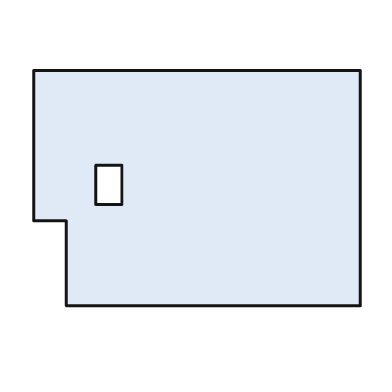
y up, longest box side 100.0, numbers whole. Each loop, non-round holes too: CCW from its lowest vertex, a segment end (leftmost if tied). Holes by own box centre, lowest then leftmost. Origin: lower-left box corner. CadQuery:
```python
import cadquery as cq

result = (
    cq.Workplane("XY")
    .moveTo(10.0, 0.0)
    .lineTo(100.0, 0.0)
    .lineTo(100.0, 72.0)
    .lineTo(0.0, 72.0)
    .lineTo(0.0, 26.0)
    .lineTo(10.0, 26.0)
    .close()
    .moveTo(19.0, 31.0)
    .lineTo(27.0, 31.0)
    .lineTo(27.0, 43.0)
    .lineTo(19.0, 43.0)
    .close()
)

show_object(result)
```